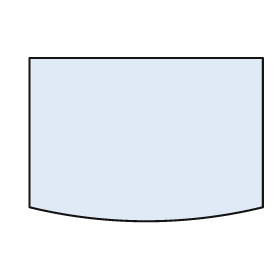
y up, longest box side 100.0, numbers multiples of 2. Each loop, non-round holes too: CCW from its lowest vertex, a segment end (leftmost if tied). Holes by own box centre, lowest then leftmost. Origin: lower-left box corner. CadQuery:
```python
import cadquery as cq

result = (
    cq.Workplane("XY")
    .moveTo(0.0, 6.0)
    .threePointArc((50.0, 0.0), (100.0, 6.0))
    .lineTo(100.0, 70.0)
    .lineTo(0.0, 70.0)
    .close()
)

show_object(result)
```